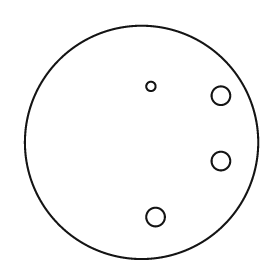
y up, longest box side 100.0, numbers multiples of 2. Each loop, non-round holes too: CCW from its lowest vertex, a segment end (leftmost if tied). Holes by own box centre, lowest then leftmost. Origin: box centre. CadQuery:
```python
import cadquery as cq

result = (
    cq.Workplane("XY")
    .moveTo(0.0, 0.0)
    .circle(50.0)
    .moveTo(6.0, -32.0)
    .circle(4.0)
    .moveTo(34.0, -8.0)
    .circle(4.0)
    .moveTo(34.0, 20.0)
    .circle(4.0)
    .moveTo(4.0, 24.0)
    .circle(2.0)
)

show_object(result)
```